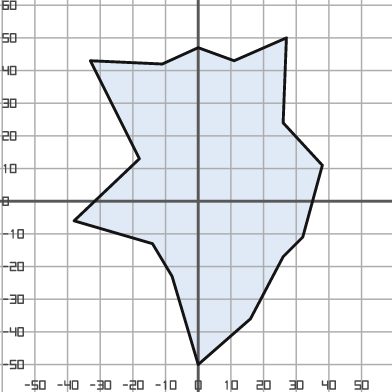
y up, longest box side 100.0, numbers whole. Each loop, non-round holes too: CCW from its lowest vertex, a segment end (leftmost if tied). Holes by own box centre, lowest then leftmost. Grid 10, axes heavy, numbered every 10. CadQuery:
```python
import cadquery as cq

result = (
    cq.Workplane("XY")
    .moveTo(0.0, -50.0)
    .lineTo(16.0, -36.0)
    .lineTo(26.0, -17.0)
    .lineTo(32.0, -11.0)
    .lineTo(38.0, 11.0)
    .lineTo(26.0, 24.0)
    .lineTo(27.0, 50.0)
    .lineTo(11.0, 43.0)
    .lineTo(0.0, 47.0)
    .lineTo(-11.0, 42.0)
    .lineTo(-33.0, 43.0)
    .lineTo(-18.0, 13.0)
    .lineTo(-38.0, -6.0)
    .lineTo(-14.0, -13.0)
    .lineTo(-8.0, -23.0)
    .close()
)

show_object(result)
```